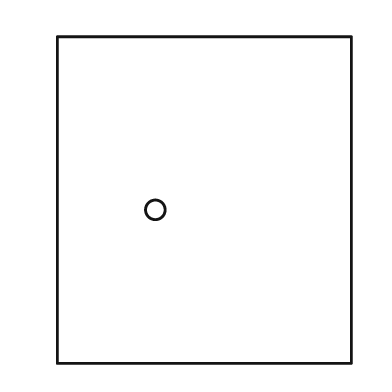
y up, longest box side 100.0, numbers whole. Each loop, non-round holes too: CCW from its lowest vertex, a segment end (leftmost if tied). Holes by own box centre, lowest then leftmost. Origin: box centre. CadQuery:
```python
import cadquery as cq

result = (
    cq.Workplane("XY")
    .moveTo(-45.0, -50.0)
    .lineTo(45.0, -50.0)
    .lineTo(45.0, 50.0)
    .lineTo(-45.0, 50.0)
    .close()
    .moveTo(-15.0, -3.0)
    .circle(3.0)
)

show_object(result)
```